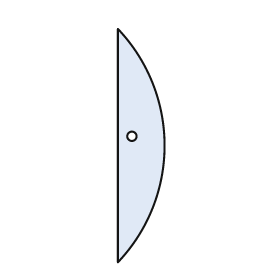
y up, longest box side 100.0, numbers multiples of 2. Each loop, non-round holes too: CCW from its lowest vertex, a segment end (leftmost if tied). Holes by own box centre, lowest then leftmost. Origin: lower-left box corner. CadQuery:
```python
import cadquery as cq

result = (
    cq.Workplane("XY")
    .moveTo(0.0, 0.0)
    .threePointArc((20.0, 50.0), (0.0, 100.0))
    .close()
    .moveTo(6.0, 54.0)
    .circle(2.0)
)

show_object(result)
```